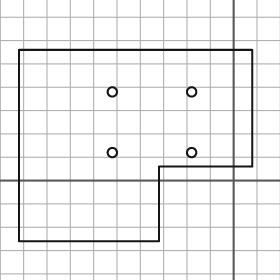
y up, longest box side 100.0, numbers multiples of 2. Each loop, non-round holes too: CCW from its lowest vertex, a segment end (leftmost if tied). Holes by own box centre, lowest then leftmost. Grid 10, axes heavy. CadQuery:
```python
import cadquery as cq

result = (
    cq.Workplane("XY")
    .moveTo(-92.0, -26.0)
    .lineTo(-32.0, -26.0)
    .lineTo(-32.0, 6.0)
    .lineTo(8.0, 6.0)
    .lineTo(8.0, 56.0)
    .lineTo(-92.0, 56.0)
    .close()
    .moveTo(-52.0, 12.0)
    .circle(2.0)
    .moveTo(-18.0, 12.0)
    .circle(2.0)
    .moveTo(-52.0, 38.0)
    .circle(2.0)
    .moveTo(-18.0, 38.0)
    .circle(2.0)
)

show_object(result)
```